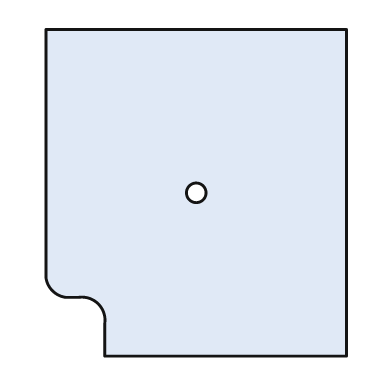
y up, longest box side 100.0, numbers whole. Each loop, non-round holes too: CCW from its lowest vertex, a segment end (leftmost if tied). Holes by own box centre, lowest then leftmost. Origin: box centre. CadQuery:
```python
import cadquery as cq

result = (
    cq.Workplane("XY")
    .moveTo(-28.0, -50.0)
    .lineTo(46.0, -50.0)
    .lineTo(46.0, 50.0)
    .lineTo(-46.0, 50.0)
    .lineTo(-46.0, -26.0)
    .threePointArc((-44.0, -30.0), (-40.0, -32.0))
    .lineTo(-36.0, -32.0)
    .threePointArc((-30.0, -34.0), (-28.0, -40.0))
    .close()
    .moveTo(0.0, 0.0)
    .circle(3.0)
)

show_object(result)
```